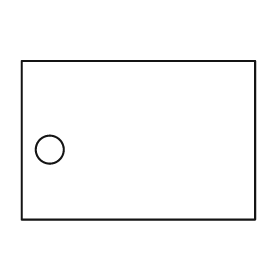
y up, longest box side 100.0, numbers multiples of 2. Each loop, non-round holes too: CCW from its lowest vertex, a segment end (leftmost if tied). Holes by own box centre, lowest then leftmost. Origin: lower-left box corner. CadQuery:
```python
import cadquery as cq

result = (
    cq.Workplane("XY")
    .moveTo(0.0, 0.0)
    .lineTo(100.0, 0.0)
    .lineTo(100.0, 68.0)
    .lineTo(0.0, 68.0)
    .close()
    .moveTo(12.0, 30.0)
    .circle(6.0)
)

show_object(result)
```